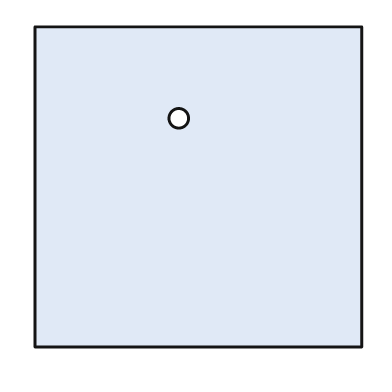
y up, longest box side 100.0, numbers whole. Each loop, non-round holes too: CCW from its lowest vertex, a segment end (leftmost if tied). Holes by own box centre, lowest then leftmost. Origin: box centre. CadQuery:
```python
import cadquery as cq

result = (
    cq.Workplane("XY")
    .moveTo(-50.0, -49.0)
    .lineTo(50.0, -49.0)
    .lineTo(50.0, 49.0)
    .lineTo(-50.0, 49.0)
    .close()
    .moveTo(-6.0, 21.0)
    .circle(3.0)
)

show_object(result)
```